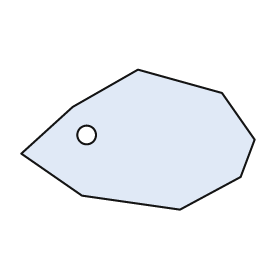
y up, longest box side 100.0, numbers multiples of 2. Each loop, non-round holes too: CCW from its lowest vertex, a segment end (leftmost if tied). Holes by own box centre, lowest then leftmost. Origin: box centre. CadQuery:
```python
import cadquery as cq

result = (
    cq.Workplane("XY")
    .moveTo(18.0, -30.0)
    .lineTo(44.0, -16.0)
    .lineTo(50.0, 0.0)
    .lineTo(36.0, 20.0)
    .lineTo(0.0, 30.0)
    .lineTo(-28.0, 14.0)
    .lineTo(-50.0, -6.0)
    .lineTo(-24.0, -24.0)
    .close()
    .moveTo(-22.0, 2.0)
    .circle(4.0)
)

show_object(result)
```